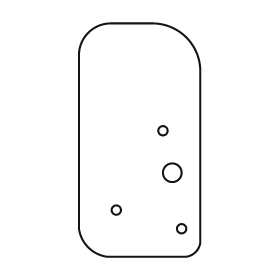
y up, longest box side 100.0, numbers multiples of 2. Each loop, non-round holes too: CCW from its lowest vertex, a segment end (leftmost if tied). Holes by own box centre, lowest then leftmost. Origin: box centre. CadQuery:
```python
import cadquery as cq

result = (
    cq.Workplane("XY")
    .moveTo(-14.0, -50.0)
    .lineTo(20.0, -50.0)
    .threePointArc((24.0, -48.0), (26.0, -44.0))
    .lineTo(26.0, 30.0)
    .threePointArc((20.0, 44.0), (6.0, 50.0))
    .lineTo(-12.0, 50.0)
    .threePointArc((-22.0, 46.0), (-26.0, 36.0))
    .lineTo(-26.0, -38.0)
    .threePointArc((-22.0, -46.0), (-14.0, -50.0))
    .close()
    .moveTo(18.0, -38.0)
    .circle(2.0)
    .moveTo(-10.0, -30.0)
    .circle(2.0)
    .moveTo(14.0, -14.0)
    .circle(4.0)
    .moveTo(10.0, 4.0)
    .circle(2.0)
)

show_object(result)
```